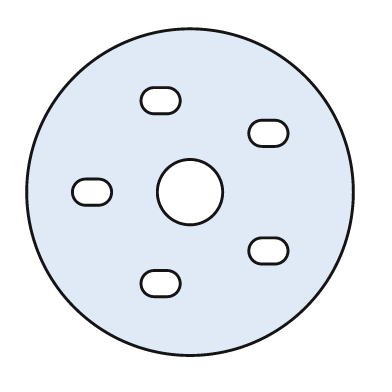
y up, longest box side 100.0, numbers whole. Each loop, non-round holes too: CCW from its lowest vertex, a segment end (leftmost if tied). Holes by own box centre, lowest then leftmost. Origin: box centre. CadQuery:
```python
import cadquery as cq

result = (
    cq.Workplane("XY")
    .moveTo(0.0, 0.0)
    .circle(50.0)
    .moveTo(-11.0, -32.0)
    .lineTo(-7.0, -32.0)
    .threePointArc((-3.0, -28.0), (-7.0, -24.0))
    .lineTo(-11.0, -24.0)
    .threePointArc((-15.0, -28.0), (-11.0, -32.0))
    .close()
    .moveTo(22.0, -22.0)
    .lineTo(26.0, -22.0)
    .threePointArc((30.0, -18.0), (26.0, -14.0))
    .lineTo(22.0, -14.0)
    .threePointArc((18.0, -18.0), (22.0, -22.0))
    .close()
    .moveTo(-32.0, -4.0)
    .lineTo(-28.0, -4.0)
    .threePointArc((-24.0, 0.0), (-28.0, 4.0))
    .lineTo(-32.0, 4.0)
    .threePointArc((-36.0, 0.0), (-32.0, -4.0))
    .close()
    .moveTo(0.0, 0.0)
    .circle(10.0)
    .moveTo(22.0, 14.0)
    .lineTo(26.0, 14.0)
    .threePointArc((30.0, 18.0), (26.0, 22.0))
    .lineTo(22.0, 22.0)
    .threePointArc((18.0, 18.0), (22.0, 14.0))
    .close()
    .moveTo(-11.0, 24.0)
    .lineTo(-7.0, 24.0)
    .threePointArc((-3.0, 28.0), (-7.0, 32.0))
    .lineTo(-11.0, 32.0)
    .threePointArc((-15.0, 28.0), (-11.0, 24.0))
    .close()
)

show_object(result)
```